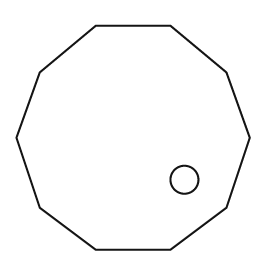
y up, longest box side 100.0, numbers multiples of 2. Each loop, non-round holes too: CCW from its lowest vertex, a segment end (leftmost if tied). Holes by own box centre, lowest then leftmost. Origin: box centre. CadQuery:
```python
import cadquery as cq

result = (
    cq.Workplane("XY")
    .moveTo(-16.0, -48.0)
    .lineTo(16.0, -48.0)
    .lineTo(40.0, -30.0)
    .lineTo(50.0, 0.0)
    .lineTo(40.0, 28.0)
    .lineTo(16.0, 48.0)
    .lineTo(-16.0, 48.0)
    .lineTo(-40.0, 28.0)
    .lineTo(-50.0, 0.0)
    .lineTo(-40.0, -30.0)
    .close()
    .moveTo(22.0, -18.0)
    .circle(6.0)
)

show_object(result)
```